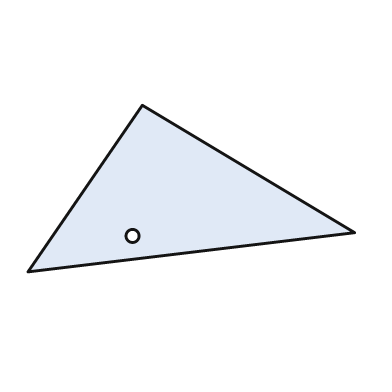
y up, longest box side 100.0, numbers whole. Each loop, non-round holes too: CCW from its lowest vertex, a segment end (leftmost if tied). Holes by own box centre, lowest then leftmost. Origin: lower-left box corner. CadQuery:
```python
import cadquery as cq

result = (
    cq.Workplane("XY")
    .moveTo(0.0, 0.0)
    .lineTo(100.0, 12.0)
    .lineTo(35.0, 51.0)
    .close()
    .moveTo(32.0, 11.0)
    .circle(2.0)
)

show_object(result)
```